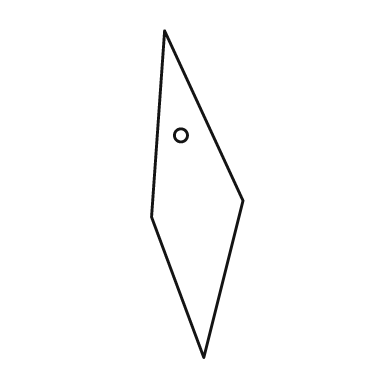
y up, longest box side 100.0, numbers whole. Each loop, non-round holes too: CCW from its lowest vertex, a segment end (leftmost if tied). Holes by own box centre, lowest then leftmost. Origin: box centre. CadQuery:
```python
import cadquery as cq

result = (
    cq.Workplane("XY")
    .moveTo(2.0, -50.0)
    .lineTo(14.0, -2.0)
    .lineTo(-10.0, 50.0)
    .lineTo(-14.0, -7.0)
    .close()
    .moveTo(-5.0, 18.0)
    .circle(2.0)
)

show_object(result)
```